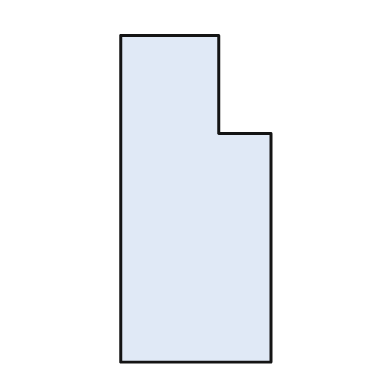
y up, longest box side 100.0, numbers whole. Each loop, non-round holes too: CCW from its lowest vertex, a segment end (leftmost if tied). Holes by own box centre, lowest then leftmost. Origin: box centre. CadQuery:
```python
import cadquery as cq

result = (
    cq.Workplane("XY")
    .moveTo(-23.0, -50.0)
    .lineTo(23.0, -50.0)
    .lineTo(23.0, 20.0)
    .lineTo(7.0, 20.0)
    .lineTo(7.0, 50.0)
    .lineTo(-23.0, 50.0)
    .close()
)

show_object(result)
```